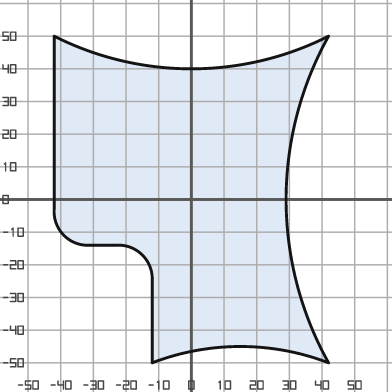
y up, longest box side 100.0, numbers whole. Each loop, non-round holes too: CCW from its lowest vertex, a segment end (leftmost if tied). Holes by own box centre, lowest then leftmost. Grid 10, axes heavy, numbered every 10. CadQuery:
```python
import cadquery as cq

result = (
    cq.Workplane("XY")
    .moveTo(-12.0, -50.0)
    .threePointArc((15.0, -45.0), (42.0, -50.0))
    .threePointArc((29.0, 0.0), (42.0, 50.0))
    .threePointArc((0.0, 40.0), (-42.0, 50.0))
    .lineTo(-42.0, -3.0)
    .threePointArc((-39.0, -11.0), (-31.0, -14.0))
    .lineTo(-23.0, -14.0)
    .threePointArc((-15.0, -17.0), (-12.0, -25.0))
    .close()
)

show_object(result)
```